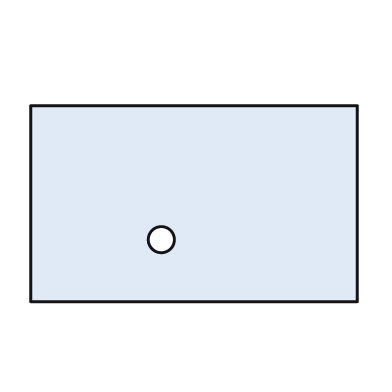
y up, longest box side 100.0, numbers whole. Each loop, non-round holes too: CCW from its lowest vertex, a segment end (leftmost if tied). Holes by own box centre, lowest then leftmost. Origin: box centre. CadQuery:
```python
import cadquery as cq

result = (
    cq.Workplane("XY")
    .moveTo(-50.0, -30.0)
    .lineTo(50.0, -30.0)
    .lineTo(50.0, 30.0)
    .lineTo(-50.0, 30.0)
    .close()
    .moveTo(-10.0, -11.0)
    .circle(4.0)
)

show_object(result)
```